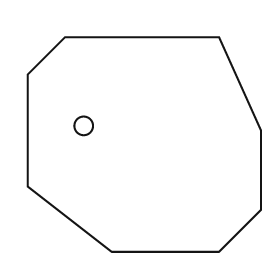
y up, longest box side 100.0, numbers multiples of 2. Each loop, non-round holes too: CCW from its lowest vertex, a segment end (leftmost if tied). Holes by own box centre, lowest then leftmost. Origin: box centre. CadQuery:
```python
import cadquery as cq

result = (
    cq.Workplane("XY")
    .moveTo(-14.0, -46.0)
    .lineTo(32.0, -46.0)
    .lineTo(50.0, -28.0)
    .lineTo(50.0, 6.0)
    .lineTo(32.0, 46.0)
    .lineTo(-34.0, 46.0)
    .lineTo(-50.0, 30.0)
    .lineTo(-50.0, -18.0)
    .close()
    .moveTo(-26.0, 8.0)
    .circle(4.0)
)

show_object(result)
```